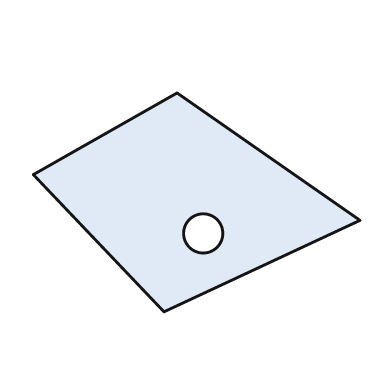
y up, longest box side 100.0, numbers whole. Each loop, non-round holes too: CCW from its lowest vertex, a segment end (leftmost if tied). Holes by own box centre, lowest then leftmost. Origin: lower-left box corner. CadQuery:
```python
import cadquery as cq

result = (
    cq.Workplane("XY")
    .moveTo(40.0, 0.0)
    .lineTo(100.0, 28.0)
    .lineTo(44.0, 67.0)
    .lineTo(0.0, 42.0)
    .close()
    .moveTo(52.0, 24.0)
    .circle(6.0)
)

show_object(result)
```